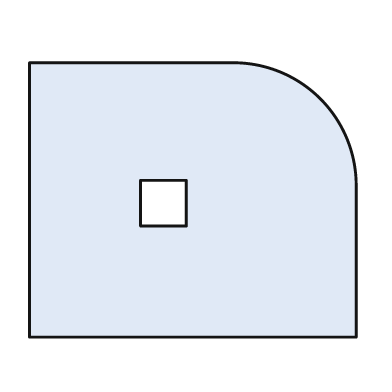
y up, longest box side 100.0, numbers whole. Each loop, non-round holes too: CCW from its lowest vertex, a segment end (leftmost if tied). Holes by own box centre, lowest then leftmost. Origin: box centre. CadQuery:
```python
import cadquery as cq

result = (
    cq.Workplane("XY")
    .moveTo(-50.0, -42.0)
    .lineTo(50.0, -42.0)
    .lineTo(50.0, 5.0)
    .threePointArc((39.0, 31.0), (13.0, 42.0))
    .lineTo(-50.0, 42.0)
    .close()
    .moveTo(-16.0, -8.0)
    .lineTo(-2.0, -8.0)
    .lineTo(-2.0, 6.0)
    .lineTo(-16.0, 6.0)
    .close()
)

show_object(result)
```